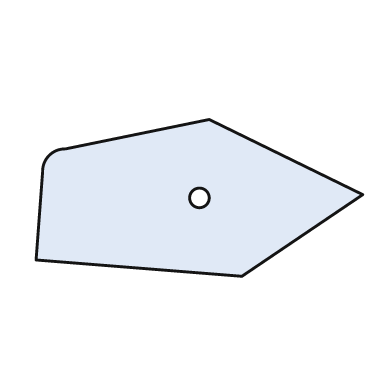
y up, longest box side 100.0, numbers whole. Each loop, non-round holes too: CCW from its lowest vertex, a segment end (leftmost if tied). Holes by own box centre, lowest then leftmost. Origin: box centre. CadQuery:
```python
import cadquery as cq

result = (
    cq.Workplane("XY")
    .moveTo(13.0, -24.0)
    .lineTo(50.0, 1.0)
    .lineTo(3.0, 24.0)
    .lineTo(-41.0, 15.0)
    .threePointArc((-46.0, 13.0), (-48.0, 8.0))
    .lineTo(-50.0, -19.0)
    .close()
    .moveTo(0.0, 0.0)
    .circle(3.0)
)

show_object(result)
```